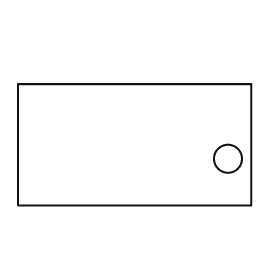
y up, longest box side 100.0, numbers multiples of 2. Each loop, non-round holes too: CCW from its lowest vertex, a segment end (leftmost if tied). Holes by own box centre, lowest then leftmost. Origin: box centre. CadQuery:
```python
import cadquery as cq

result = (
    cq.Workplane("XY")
    .moveTo(-50.0, -26.0)
    .lineTo(50.0, -26.0)
    .lineTo(50.0, 26.0)
    .lineTo(-50.0, 26.0)
    .close()
    .moveTo(40.0, -6.0)
    .circle(6.0)
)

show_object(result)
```